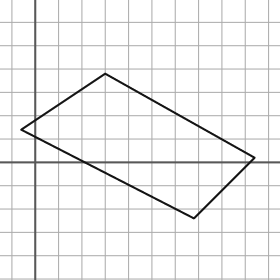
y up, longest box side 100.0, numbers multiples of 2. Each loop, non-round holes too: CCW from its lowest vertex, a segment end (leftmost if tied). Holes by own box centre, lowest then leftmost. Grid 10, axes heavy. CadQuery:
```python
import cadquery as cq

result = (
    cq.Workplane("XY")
    .moveTo(68.0, -24.0)
    .lineTo(94.0, 2.0)
    .lineTo(30.0, 38.0)
    .lineTo(-6.0, 14.0)
    .close()
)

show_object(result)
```